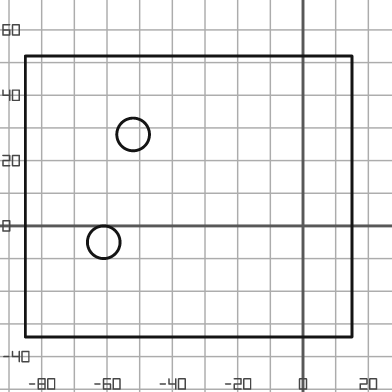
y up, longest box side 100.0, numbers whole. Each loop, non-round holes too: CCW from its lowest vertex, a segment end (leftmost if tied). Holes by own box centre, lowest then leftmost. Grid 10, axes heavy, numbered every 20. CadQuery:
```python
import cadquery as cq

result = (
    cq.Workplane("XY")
    .moveTo(-85.0, -34.0)
    .lineTo(15.0, -34.0)
    .lineTo(15.0, 52.0)
    .lineTo(-85.0, 52.0)
    .close()
    .moveTo(-61.0, -5.0)
    .circle(5.0)
    .moveTo(-52.0, 28.0)
    .circle(5.0)
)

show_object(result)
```